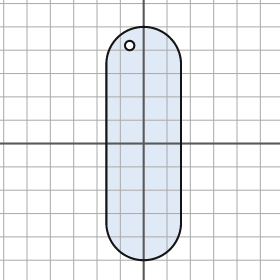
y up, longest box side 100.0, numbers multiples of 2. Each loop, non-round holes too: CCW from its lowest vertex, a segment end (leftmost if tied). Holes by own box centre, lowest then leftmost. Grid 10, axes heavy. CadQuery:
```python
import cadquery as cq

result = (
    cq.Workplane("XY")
    .moveTo(-16.0, -34.0)
    .threePointArc((0.0, -50.0), (16.0, -34.0))
    .lineTo(16.0, 34.0)
    .threePointArc((0.0, 50.0), (-16.0, 34.0))
    .close()
    .moveTo(-6.0, 42.0)
    .circle(2.0)
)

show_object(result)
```